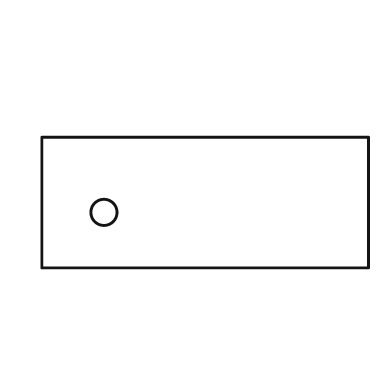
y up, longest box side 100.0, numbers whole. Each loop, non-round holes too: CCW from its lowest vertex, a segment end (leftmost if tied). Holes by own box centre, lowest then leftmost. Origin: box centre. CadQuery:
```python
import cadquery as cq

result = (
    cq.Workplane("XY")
    .moveTo(-50.0, -20.0)
    .lineTo(50.0, -20.0)
    .lineTo(50.0, 20.0)
    .lineTo(-50.0, 20.0)
    .close()
    .moveTo(-31.0, -3.0)
    .circle(4.0)
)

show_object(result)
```